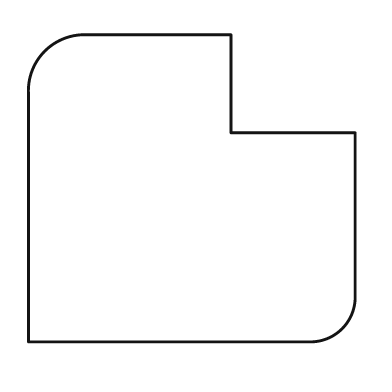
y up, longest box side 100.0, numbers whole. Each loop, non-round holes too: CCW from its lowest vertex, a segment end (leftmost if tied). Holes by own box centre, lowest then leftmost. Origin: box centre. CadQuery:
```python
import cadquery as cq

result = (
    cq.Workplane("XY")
    .moveTo(-50.0, -47.0)
    .lineTo(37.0, -47.0)
    .threePointArc((46.0, -43.0), (50.0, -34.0))
    .lineTo(50.0, 17.0)
    .lineTo(12.0, 17.0)
    .lineTo(12.0, 47.0)
    .lineTo(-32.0, 47.0)
    .threePointArc((-45.0, 42.0), (-50.0, 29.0))
    .close()
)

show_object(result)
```